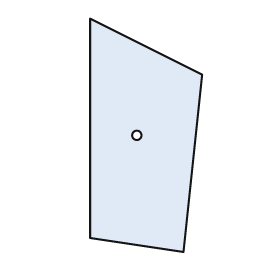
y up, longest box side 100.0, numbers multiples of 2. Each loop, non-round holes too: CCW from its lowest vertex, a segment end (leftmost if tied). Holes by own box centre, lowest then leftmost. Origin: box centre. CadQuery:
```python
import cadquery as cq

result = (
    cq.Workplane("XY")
    .moveTo(16.0, -50.0)
    .lineTo(24.0, 26.0)
    .lineTo(-24.0, 50.0)
    .lineTo(-24.0, -44.0)
    .close()
    .moveTo(-4.0, 0.0)
    .circle(2.0)
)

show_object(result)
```